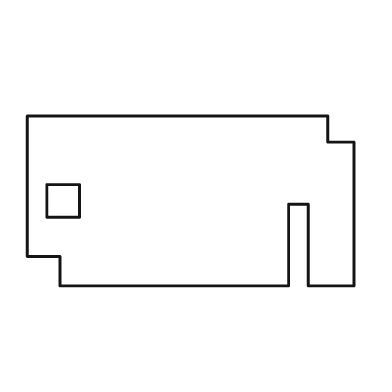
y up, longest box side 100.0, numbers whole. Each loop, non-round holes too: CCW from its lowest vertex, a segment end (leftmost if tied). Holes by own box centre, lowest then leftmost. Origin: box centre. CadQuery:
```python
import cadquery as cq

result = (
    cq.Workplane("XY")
    .moveTo(-40.0, -26.0)
    .lineTo(30.0, -26.0)
    .lineTo(30.0, -1.0)
    .lineTo(36.0, -1.0)
    .lineTo(36.0, -26.0)
    .lineTo(50.0, -26.0)
    .lineTo(50.0, 18.0)
    .lineTo(42.0, 18.0)
    .lineTo(42.0, 26.0)
    .lineTo(-50.0, 26.0)
    .lineTo(-50.0, -17.0)
    .lineTo(-40.0, -17.0)
    .close()
    .moveTo(-44.0, -5.0)
    .lineTo(-34.0, -5.0)
    .lineTo(-34.0, 5.0)
    .lineTo(-44.0, 5.0)
    .close()
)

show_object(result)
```